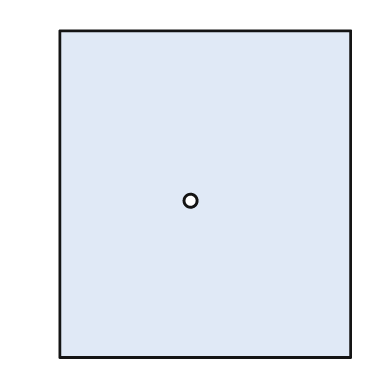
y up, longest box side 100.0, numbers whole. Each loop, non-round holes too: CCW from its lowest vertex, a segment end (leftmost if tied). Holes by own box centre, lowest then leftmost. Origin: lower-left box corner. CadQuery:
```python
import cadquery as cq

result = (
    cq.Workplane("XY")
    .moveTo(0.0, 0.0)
    .lineTo(89.0, 0.0)
    .lineTo(89.0, 100.0)
    .lineTo(0.0, 100.0)
    .close()
    .moveTo(40.0, 48.0)
    .circle(2.0)
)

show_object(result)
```